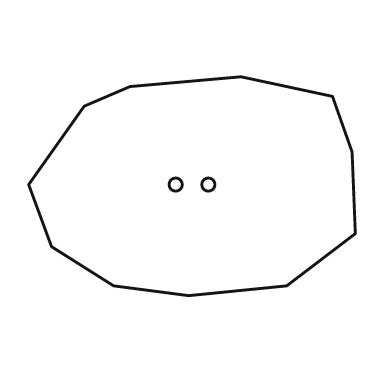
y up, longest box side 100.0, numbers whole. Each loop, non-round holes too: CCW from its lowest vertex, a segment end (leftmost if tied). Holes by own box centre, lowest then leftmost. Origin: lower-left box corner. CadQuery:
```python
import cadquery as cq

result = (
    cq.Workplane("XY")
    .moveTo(49.0, 0.0)
    .lineTo(79.0, 3.0)
    .lineTo(100.0, 19.0)
    .lineTo(99.0, 44.0)
    .lineTo(93.0, 61.0)
    .lineTo(65.0, 67.0)
    .lineTo(31.0, 64.0)
    .lineTo(17.0, 58.0)
    .lineTo(0.0, 34.0)
    .lineTo(7.0, 15.0)
    .lineTo(26.0, 3.0)
    .close()
    .moveTo(45.0, 34.0)
    .circle(2.0)
    .moveTo(55.0, 34.0)
    .circle(2.0)
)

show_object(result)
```